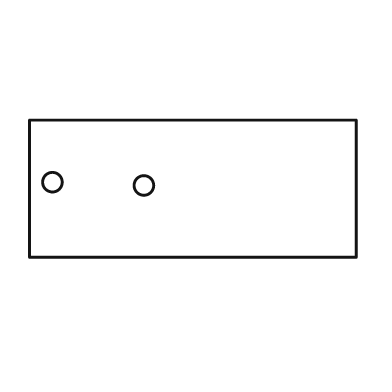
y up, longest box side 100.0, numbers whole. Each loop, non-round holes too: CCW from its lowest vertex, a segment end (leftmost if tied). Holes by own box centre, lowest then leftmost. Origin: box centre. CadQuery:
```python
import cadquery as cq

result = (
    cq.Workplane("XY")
    .moveTo(-50.0, -21.0)
    .lineTo(50.0, -21.0)
    .lineTo(50.0, 21.0)
    .lineTo(-50.0, 21.0)
    .close()
    .moveTo(-15.0, 1.0)
    .circle(3.0)
    .moveTo(-43.0, 2.0)
    .circle(3.0)
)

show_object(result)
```